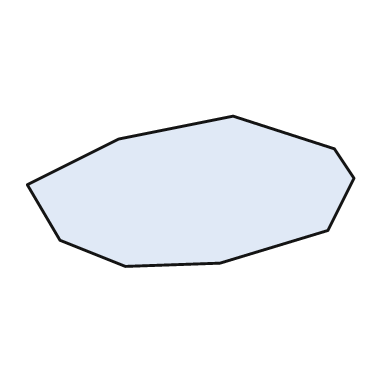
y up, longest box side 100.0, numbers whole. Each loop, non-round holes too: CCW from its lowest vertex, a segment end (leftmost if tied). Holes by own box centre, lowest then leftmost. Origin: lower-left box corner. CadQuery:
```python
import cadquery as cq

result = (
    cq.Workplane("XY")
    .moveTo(30.0, 0.0)
    .lineTo(59.0, 1.0)
    .lineTo(92.0, 11.0)
    .lineTo(100.0, 27.0)
    .lineTo(94.0, 36.0)
    .lineTo(63.0, 46.0)
    .lineTo(28.0, 39.0)
    .lineTo(0.0, 25.0)
    .lineTo(10.0, 8.0)
    .close()
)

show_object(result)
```